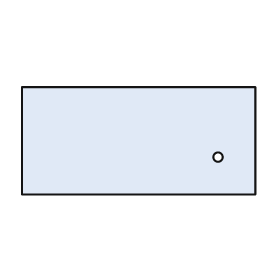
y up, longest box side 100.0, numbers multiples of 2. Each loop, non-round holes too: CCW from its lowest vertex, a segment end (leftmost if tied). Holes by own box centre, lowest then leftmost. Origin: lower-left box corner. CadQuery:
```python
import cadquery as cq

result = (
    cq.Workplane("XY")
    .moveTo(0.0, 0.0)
    .lineTo(100.0, 0.0)
    .lineTo(100.0, 46.0)
    .lineTo(0.0, 46.0)
    .close()
    .moveTo(84.0, 16.0)
    .circle(2.0)
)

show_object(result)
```